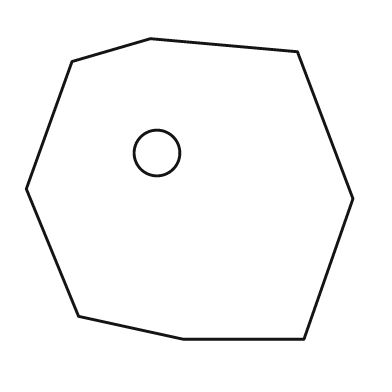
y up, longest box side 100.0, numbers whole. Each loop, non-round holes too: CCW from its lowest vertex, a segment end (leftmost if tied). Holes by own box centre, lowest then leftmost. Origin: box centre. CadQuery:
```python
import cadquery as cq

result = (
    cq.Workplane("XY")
    .moveTo(-2.0, -46.0)
    .lineTo(35.0, -46.0)
    .lineTo(50.0, -3.0)
    .lineTo(33.0, 42.0)
    .lineTo(-12.0, 46.0)
    .lineTo(-36.0, 39.0)
    .lineTo(-50.0, 0.0)
    .lineTo(-34.0, -39.0)
    .close()
    .moveTo(-10.0, 11.0)
    .circle(7.0)
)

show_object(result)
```